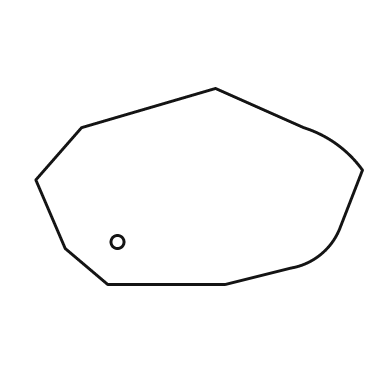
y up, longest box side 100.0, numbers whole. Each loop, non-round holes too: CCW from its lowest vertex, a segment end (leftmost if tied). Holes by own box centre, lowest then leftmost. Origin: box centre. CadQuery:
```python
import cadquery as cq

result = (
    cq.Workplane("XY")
    .moveTo(-28.0, -30.0)
    .lineTo(8.0, -30.0)
    .lineTo(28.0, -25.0)
    .threePointArc((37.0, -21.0), (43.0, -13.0))
    .lineTo(50.0, 5.0)
    .threePointArc((42.0, 13.0), (32.0, 18.0))
    .lineTo(5.0, 30.0)
    .lineTo(-36.0, 18.0)
    .lineTo(-50.0, 2.0)
    .lineTo(-41.0, -19.0)
    .close()
    .moveTo(-25.0, -17.0)
    .circle(2.0)
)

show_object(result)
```